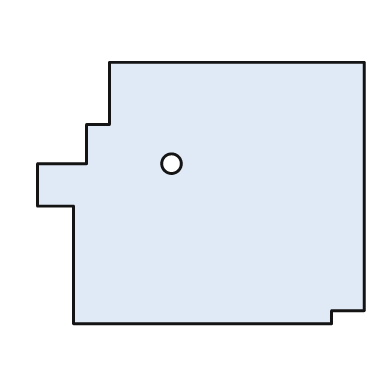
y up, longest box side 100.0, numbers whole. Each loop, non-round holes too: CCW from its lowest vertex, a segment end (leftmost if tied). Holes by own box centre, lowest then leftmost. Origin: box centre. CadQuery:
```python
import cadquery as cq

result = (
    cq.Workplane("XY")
    .moveTo(-39.0, -40.0)
    .lineTo(40.0, -40.0)
    .lineTo(40.0, -36.0)
    .lineTo(50.0, -36.0)
    .lineTo(50.0, 40.0)
    .lineTo(-28.0, 40.0)
    .lineTo(-28.0, 21.0)
    .lineTo(-35.0, 21.0)
    .lineTo(-35.0, 9.0)
    .lineTo(-50.0, 9.0)
    .lineTo(-50.0, -4.0)
    .lineTo(-39.0, -4.0)
    .close()
    .moveTo(-9.0, 9.0)
    .circle(3.0)
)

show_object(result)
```